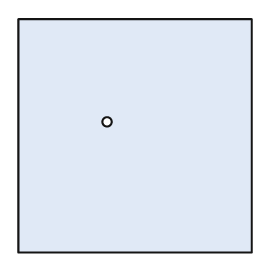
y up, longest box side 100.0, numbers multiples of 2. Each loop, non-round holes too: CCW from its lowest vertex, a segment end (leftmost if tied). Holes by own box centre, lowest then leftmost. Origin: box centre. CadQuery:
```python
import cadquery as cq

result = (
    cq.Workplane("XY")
    .moveTo(-50.0, -50.0)
    .lineTo(50.0, -50.0)
    .lineTo(50.0, 50.0)
    .lineTo(-50.0, 50.0)
    .close()
    .moveTo(-12.0, 6.0)
    .circle(2.0)
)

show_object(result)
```